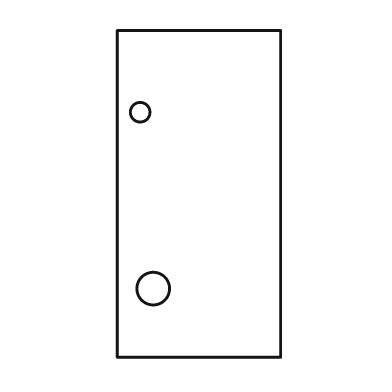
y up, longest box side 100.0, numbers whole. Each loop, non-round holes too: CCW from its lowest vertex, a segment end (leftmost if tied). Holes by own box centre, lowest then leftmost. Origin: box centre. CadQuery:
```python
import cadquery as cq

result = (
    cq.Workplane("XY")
    .moveTo(-25.0, -50.0)
    .lineTo(25.0, -50.0)
    .lineTo(25.0, 50.0)
    .lineTo(-25.0, 50.0)
    .close()
    .moveTo(-14.0, -29.0)
    .circle(5.0)
    .moveTo(-18.0, 25.0)
    .circle(3.0)
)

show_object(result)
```